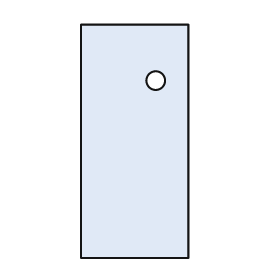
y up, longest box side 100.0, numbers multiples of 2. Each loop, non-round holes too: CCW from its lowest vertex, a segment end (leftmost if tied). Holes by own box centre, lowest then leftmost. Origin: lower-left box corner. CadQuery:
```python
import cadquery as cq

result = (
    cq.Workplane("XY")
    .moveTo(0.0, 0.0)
    .lineTo(46.0, 0.0)
    .lineTo(46.0, 100.0)
    .lineTo(0.0, 100.0)
    .close()
    .moveTo(32.0, 76.0)
    .circle(4.0)
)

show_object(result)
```